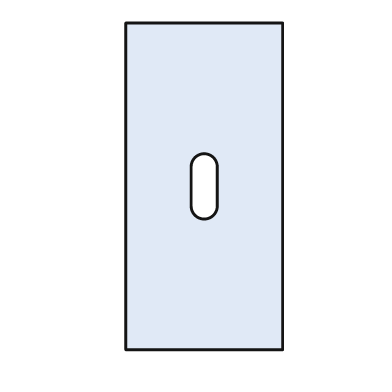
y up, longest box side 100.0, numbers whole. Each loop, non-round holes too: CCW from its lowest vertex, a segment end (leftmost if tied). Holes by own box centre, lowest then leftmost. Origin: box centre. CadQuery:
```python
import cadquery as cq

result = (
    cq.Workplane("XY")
    .moveTo(-24.0, -50.0)
    .lineTo(24.0, -50.0)
    .lineTo(24.0, 50.0)
    .lineTo(-24.0, 50.0)
    .close()
    .moveTo(-4.0, -6.0)
    .threePointArc((0.0, -10.0), (4.0, -6.0))
    .lineTo(4.0, 6.0)
    .threePointArc((0.0, 10.0), (-4.0, 6.0))
    .close()
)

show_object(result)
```